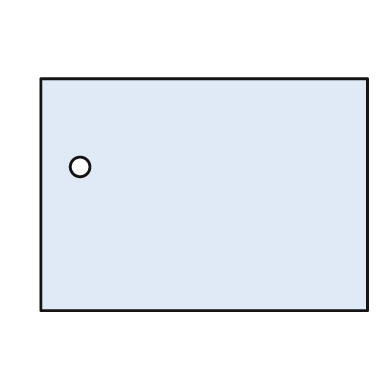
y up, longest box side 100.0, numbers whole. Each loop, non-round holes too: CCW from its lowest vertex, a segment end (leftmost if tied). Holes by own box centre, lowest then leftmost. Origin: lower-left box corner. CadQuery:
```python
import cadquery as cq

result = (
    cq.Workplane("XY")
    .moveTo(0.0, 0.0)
    .lineTo(100.0, 0.0)
    .lineTo(100.0, 71.0)
    .lineTo(0.0, 71.0)
    .close()
    .moveTo(12.0, 44.0)
    .circle(3.0)
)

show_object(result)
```